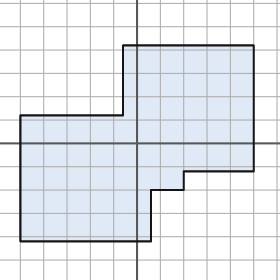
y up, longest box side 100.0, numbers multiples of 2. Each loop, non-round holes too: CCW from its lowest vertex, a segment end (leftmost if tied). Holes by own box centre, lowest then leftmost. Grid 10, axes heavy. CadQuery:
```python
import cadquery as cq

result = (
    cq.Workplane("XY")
    .moveTo(-50.0, -42.0)
    .lineTo(6.0, -42.0)
    .lineTo(6.0, -20.0)
    .lineTo(20.0, -20.0)
    .lineTo(20.0, -12.0)
    .lineTo(50.0, -12.0)
    .lineTo(50.0, 42.0)
    .lineTo(-6.0, 42.0)
    .lineTo(-6.0, 12.0)
    .lineTo(-50.0, 12.0)
    .close()
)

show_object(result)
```